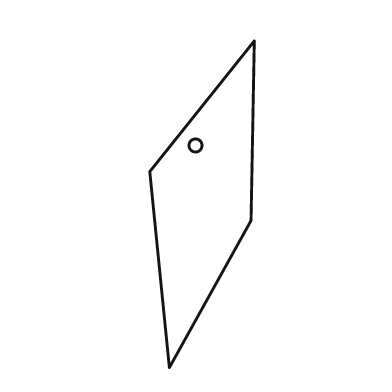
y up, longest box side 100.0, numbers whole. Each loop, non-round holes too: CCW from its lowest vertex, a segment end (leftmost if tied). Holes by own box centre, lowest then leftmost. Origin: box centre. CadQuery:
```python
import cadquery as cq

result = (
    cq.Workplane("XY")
    .moveTo(-10.0, -50.0)
    .lineTo(15.0, -5.0)
    .lineTo(16.0, 50.0)
    .lineTo(-16.0, 10.0)
    .close()
    .moveTo(-2.0, 18.0)
    .circle(2.0)
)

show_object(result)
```